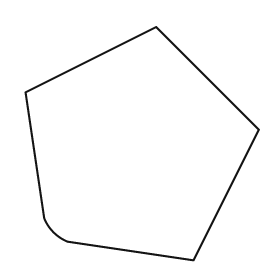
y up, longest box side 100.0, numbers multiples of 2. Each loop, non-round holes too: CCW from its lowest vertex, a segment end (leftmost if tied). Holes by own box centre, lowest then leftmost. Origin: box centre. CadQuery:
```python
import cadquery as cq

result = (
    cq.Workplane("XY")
    .moveTo(22.0, -50.0)
    .lineTo(50.0, 6.0)
    .lineTo(6.0, 50.0)
    .lineTo(-50.0, 22.0)
    .lineTo(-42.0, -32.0)
    .threePointArc((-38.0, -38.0), (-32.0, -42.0))
    .close()
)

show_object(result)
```